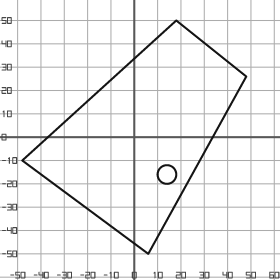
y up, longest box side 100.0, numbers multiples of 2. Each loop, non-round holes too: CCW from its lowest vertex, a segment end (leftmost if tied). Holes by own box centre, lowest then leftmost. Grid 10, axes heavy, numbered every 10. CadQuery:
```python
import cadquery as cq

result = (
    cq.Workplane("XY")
    .moveTo(6.0, -50.0)
    .lineTo(48.0, 26.0)
    .lineTo(18.0, 50.0)
    .lineTo(-48.0, -10.0)
    .close()
    .moveTo(14.0, -16.0)
    .circle(4.0)
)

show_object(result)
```